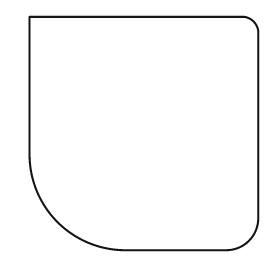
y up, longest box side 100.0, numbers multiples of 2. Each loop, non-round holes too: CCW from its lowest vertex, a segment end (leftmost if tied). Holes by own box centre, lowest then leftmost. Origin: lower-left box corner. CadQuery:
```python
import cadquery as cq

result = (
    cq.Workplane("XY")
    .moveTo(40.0, 0.0)
    .lineTo(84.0, 0.0)
    .threePointArc((94.0, 4.0), (98.0, 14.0))
    .lineTo(98.0, 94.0)
    .threePointArc((96.0, 98.0), (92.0, 100.0))
    .lineTo(0.0, 100.0)
    .lineTo(0.0, 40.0)
    .threePointArc((12.0, 12.0), (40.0, 0.0))
    .close()
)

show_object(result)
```